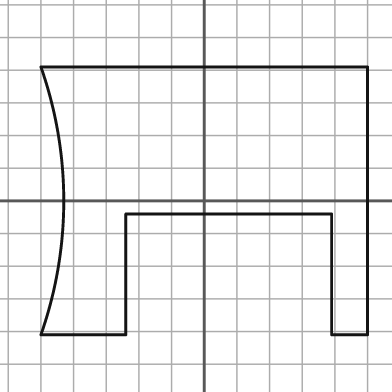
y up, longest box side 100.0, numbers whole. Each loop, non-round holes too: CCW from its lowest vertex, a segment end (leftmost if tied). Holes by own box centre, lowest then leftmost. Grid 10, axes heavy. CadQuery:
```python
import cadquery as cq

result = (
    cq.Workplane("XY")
    .moveTo(-50.0, -41.0)
    .lineTo(-24.0, -41.0)
    .lineTo(-24.0, -4.0)
    .lineTo(39.0, -4.0)
    .lineTo(39.0, -41.0)
    .lineTo(50.0, -41.0)
    .lineTo(50.0, 41.0)
    .lineTo(-50.0, 41.0)
    .threePointArc((-43.0, 0.0), (-50.0, -41.0))
    .close()
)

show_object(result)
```